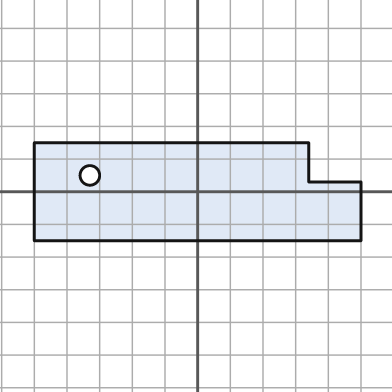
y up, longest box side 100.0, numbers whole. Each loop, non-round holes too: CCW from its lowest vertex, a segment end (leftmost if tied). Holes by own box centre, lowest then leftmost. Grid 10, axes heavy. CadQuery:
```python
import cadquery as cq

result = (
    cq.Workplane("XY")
    .moveTo(-50.0, -15.0)
    .lineTo(50.0, -15.0)
    .lineTo(50.0, 3.0)
    .lineTo(34.0, 3.0)
    .lineTo(34.0, 15.0)
    .lineTo(-50.0, 15.0)
    .close()
    .moveTo(-33.0, 5.0)
    .circle(3.0)
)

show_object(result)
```